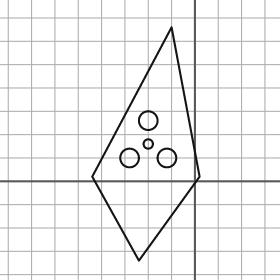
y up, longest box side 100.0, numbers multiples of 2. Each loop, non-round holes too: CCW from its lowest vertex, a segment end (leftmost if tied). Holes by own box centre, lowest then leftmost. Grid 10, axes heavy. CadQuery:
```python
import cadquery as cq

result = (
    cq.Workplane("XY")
    .moveTo(-24.0, -34.0)
    .lineTo(2.0, 2.0)
    .lineTo(-10.0, 66.0)
    .lineTo(-44.0, 2.0)
    .close()
    .moveTo(-28.0, 10.0)
    .circle(4.0)
    .moveTo(-12.0, 10.0)
    .circle(4.0)
    .moveTo(-20.0, 16.0)
    .circle(2.0)
    .moveTo(-20.0, 26.0)
    .circle(4.0)
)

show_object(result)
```